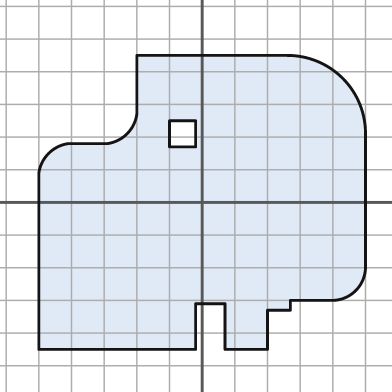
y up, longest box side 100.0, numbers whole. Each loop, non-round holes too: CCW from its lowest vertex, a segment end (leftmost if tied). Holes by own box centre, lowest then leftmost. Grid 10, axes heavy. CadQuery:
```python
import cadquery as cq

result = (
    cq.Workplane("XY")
    .moveTo(-50.0, -45.0)
    .lineTo(-2.0, -45.0)
    .lineTo(-2.0, -31.0)
    .lineTo(7.0, -31.0)
    .lineTo(7.0, -45.0)
    .lineTo(20.0, -45.0)
    .lineTo(20.0, -33.0)
    .lineTo(27.0, -33.0)
    .lineTo(27.0, -30.0)
    .lineTo(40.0, -30.0)
    .threePointArc((47.0, -27.0), (50.0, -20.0))
    .lineTo(50.0, 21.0)
    .threePointArc((43.0, 38.0), (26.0, 45.0))
    .lineTo(-20.0, 45.0)
    .lineTo(-20.0, 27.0)
    .threePointArc((-23.0, 21.0), (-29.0, 18.0))
    .lineTo(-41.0, 18.0)
    .threePointArc((-47.0, 15.0), (-50.0, 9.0))
    .close()
    .moveTo(-10.0, 17.0)
    .lineTo(-2.0, 17.0)
    .lineTo(-2.0, 25.0)
    .lineTo(-10.0, 25.0)
    .close()
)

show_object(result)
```